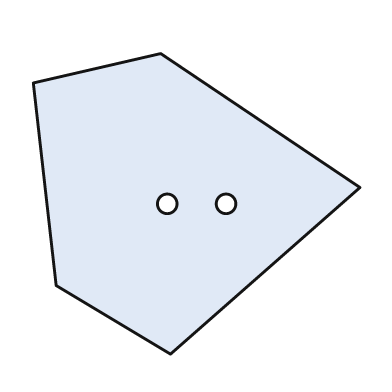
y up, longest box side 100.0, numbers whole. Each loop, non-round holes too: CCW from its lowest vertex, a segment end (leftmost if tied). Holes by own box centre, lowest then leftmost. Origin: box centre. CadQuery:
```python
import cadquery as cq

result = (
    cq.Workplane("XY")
    .moveTo(-8.0, -46.0)
    .lineTo(50.0, 5.0)
    .lineTo(-11.0, 46.0)
    .lineTo(-50.0, 37.0)
    .lineTo(-43.0, -25.0)
    .close()
    .moveTo(-9.0, 0.0)
    .circle(3.0)
    .moveTo(9.0, 0.0)
    .circle(3.0)
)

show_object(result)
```